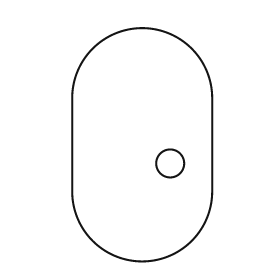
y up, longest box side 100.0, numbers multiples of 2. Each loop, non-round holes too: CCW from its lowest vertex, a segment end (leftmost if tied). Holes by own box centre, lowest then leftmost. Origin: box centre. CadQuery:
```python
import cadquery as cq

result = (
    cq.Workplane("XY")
    .moveTo(-30.0, -20.0)
    .threePointArc((0.0, -50.0), (30.0, -20.0))
    .lineTo(30.0, 20.0)
    .threePointArc((0.0, 50.0), (-30.0, 20.0))
    .close()
    .moveTo(12.0, -8.0)
    .circle(6.0)
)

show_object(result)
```